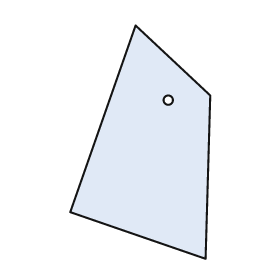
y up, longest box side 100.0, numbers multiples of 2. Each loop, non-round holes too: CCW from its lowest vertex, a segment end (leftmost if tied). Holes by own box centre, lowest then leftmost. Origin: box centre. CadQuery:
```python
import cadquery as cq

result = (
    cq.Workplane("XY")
    .moveTo(28.0, -50.0)
    .lineTo(30.0, 20.0)
    .lineTo(-2.0, 50.0)
    .lineTo(-30.0, -30.0)
    .close()
    .moveTo(12.0, 18.0)
    .circle(2.0)
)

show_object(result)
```